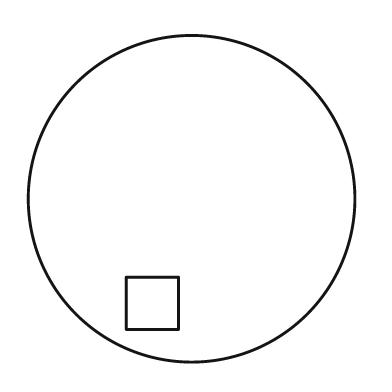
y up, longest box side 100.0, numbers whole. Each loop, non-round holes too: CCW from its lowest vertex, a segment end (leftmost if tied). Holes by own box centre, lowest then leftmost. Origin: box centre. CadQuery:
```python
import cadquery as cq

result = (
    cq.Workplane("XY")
    .moveTo(0.0, 0.0)
    .circle(50.0)
    .moveTo(-20.0, -40.0)
    .lineTo(-4.0, -40.0)
    .lineTo(-4.0, -24.0)
    .lineTo(-20.0, -24.0)
    .close()
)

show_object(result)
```